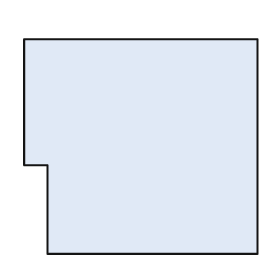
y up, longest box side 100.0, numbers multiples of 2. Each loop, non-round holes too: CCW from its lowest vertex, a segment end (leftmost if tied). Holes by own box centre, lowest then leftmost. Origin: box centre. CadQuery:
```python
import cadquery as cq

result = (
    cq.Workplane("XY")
    .moveTo(-40.0, -46.0)
    .lineTo(50.0, -46.0)
    .lineTo(50.0, 46.0)
    .lineTo(-50.0, 46.0)
    .lineTo(-50.0, -8.0)
    .lineTo(-40.0, -8.0)
    .close()
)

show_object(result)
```